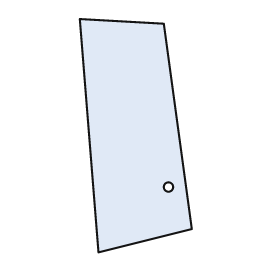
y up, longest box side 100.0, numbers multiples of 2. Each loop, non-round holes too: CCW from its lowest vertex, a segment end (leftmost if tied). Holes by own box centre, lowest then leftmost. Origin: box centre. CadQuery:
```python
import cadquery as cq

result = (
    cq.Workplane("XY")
    .moveTo(-16.0, -50.0)
    .lineTo(24.0, -40.0)
    .lineTo(12.0, 48.0)
    .lineTo(-24.0, 50.0)
    .close()
    .moveTo(14.0, -22.0)
    .circle(2.0)
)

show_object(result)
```